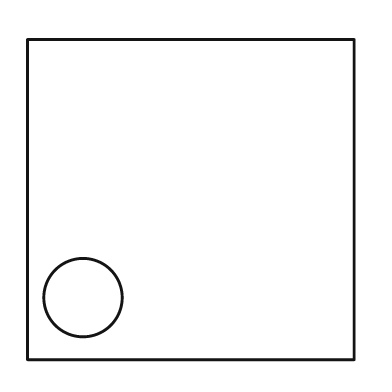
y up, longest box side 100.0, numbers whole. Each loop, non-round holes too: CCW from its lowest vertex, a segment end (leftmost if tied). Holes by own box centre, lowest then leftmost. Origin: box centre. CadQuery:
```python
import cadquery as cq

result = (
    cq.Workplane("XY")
    .moveTo(-50.0, -49.0)
    .lineTo(50.0, -49.0)
    .lineTo(50.0, 49.0)
    .lineTo(-50.0, 49.0)
    .close()
    .moveTo(-33.0, -30.0)
    .circle(12.0)
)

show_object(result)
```